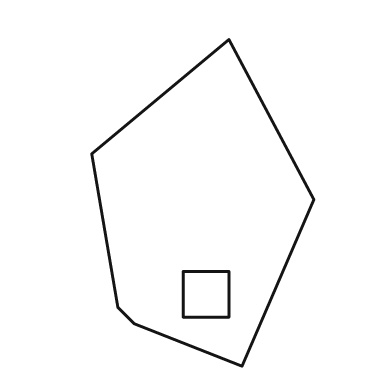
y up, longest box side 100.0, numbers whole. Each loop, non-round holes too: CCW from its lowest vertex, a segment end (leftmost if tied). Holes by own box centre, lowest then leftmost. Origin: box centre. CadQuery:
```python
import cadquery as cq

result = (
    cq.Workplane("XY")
    .moveTo(12.0, -50.0)
    .lineTo(34.0, 1.0)
    .lineTo(8.0, 50.0)
    .lineTo(-34.0, 15.0)
    .lineTo(-26.0, -32.0)
    .lineTo(-21.0, -37.0)
    .close()
    .moveTo(-6.0, -35.0)
    .lineTo(8.0, -35.0)
    .lineTo(8.0, -21.0)
    .lineTo(-6.0, -21.0)
    .close()
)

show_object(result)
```